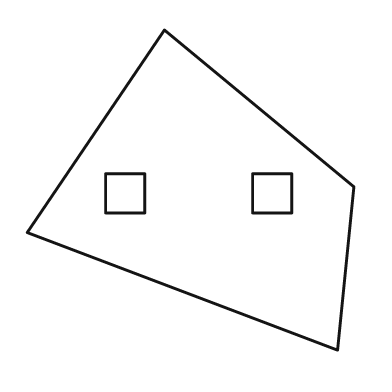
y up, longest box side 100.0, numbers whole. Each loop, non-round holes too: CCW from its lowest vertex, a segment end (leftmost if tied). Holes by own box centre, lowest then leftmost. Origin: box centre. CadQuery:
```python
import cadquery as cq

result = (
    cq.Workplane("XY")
    .moveTo(45.0, -49.0)
    .lineTo(50.0, 1.0)
    .lineTo(-8.0, 49.0)
    .lineTo(-50.0, -13.0)
    .close()
    .moveTo(-26.0, -7.0)
    .lineTo(-14.0, -7.0)
    .lineTo(-14.0, 5.0)
    .lineTo(-26.0, 5.0)
    .close()
    .moveTo(19.0, -7.0)
    .lineTo(31.0, -7.0)
    .lineTo(31.0, 5.0)
    .lineTo(19.0, 5.0)
    .close()
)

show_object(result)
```